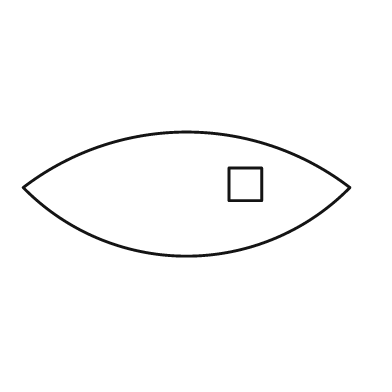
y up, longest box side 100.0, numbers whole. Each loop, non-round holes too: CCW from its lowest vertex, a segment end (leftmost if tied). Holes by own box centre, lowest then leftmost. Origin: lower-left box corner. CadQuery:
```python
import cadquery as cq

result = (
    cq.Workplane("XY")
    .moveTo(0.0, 21.0)
    .threePointArc((50.0, 0.0), (100.0, 21.0))
    .threePointArc((50.0, 38.0), (0.0, 21.0))
    .close()
    .moveTo(63.0, 17.0)
    .lineTo(73.0, 17.0)
    .lineTo(73.0, 27.0)
    .lineTo(63.0, 27.0)
    .close()
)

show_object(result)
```